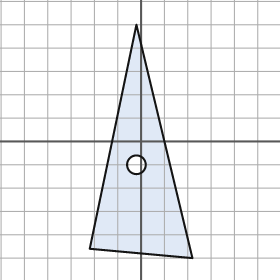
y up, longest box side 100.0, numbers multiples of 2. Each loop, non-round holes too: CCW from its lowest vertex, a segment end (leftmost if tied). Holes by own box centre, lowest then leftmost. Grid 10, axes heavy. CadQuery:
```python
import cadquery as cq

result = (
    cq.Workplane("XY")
    .moveTo(22.0, -50.0)
    .lineTo(-2.0, 50.0)
    .lineTo(-22.0, -46.0)
    .close()
    .moveTo(-2.0, -10.0)
    .circle(4.0)
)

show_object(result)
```